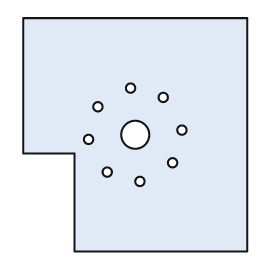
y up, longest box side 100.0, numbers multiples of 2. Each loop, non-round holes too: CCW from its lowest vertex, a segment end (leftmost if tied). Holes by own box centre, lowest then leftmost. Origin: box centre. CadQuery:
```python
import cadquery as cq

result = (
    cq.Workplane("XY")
    .moveTo(-26.0, -50.0)
    .lineTo(48.0, -50.0)
    .lineTo(48.0, 50.0)
    .lineTo(-48.0, 50.0)
    .lineTo(-48.0, -8.0)
    .lineTo(-26.0, -8.0)
    .close()
    .moveTo(2.0, -20.0)
    .circle(2.0)
    .moveTo(-12.0, -16.0)
    .circle(2.0)
    .moveTo(16.0, -12.0)
    .circle(2.0)
    .moveTo(-20.0, -2.0)
    .circle(2.0)
    .moveTo(0.0, 0.0)
    .circle(6.0)
    .moveTo(20.0, 2.0)
    .circle(2.0)
    .moveTo(-16.0, 12.0)
    .circle(2.0)
    .moveTo(12.0, 16.0)
    .circle(2.0)
    .moveTo(-2.0, 20.0)
    .circle(2.0)
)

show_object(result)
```